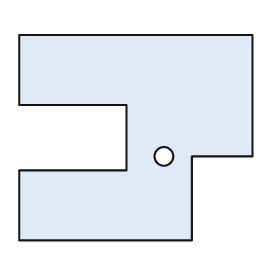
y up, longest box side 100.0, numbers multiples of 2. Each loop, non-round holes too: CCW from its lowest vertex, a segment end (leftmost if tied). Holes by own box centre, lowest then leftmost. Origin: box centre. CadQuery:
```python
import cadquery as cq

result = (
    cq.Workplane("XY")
    .moveTo(-50.0, -44.0)
    .lineTo(24.0, -44.0)
    .lineTo(24.0, -8.0)
    .lineTo(50.0, -8.0)
    .lineTo(50.0, 44.0)
    .lineTo(-50.0, 44.0)
    .lineTo(-50.0, 14.0)
    .lineTo(-4.0, 14.0)
    .lineTo(-4.0, -14.0)
    .lineTo(-50.0, -14.0)
    .close()
    .moveTo(12.0, -8.0)
    .circle(4.0)
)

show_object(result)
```